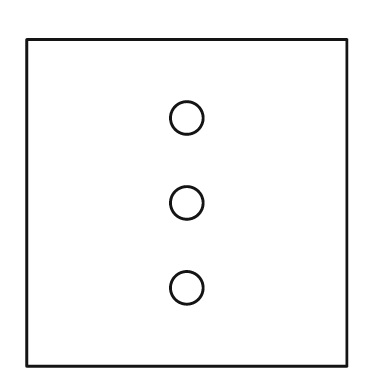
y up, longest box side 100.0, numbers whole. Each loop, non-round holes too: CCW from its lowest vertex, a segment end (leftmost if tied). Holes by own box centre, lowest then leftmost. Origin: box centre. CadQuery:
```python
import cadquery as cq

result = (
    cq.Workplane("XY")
    .moveTo(-49.0, -50.0)
    .lineTo(49.0, -50.0)
    .lineTo(49.0, 50.0)
    .lineTo(-49.0, 50.0)
    .close()
    .moveTo(0.0, -26.0)
    .circle(5.0)
    .moveTo(0.0, 0.0)
    .circle(5.0)
    .moveTo(0.0, 26.0)
    .circle(5.0)
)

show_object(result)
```